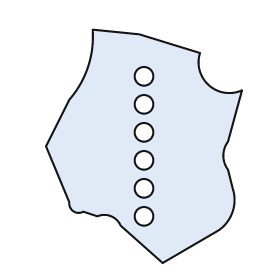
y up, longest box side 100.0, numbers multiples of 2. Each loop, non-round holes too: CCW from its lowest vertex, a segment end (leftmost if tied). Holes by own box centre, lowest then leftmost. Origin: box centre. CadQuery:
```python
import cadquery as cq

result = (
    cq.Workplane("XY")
    .moveTo(8.0, -50.0)
    .lineTo(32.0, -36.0)
    .threePointArc((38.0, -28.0), (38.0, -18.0))
    .lineTo(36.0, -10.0)
    .threePointArc((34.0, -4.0), (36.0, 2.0))
    .lineTo(42.0, 24.0)
    .threePointArc((28.0, 26.0), (24.0, 40.0))
    .lineTo(-2.0, 48.0)
    .lineTo(-22.0, 50.0)
    .threePointArc((-24.0, 34.0), (-32.0, 20.0))
    .lineTo(-42.0, 0.0)
    .lineTo(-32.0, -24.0)
    .threePointArc((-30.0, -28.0), (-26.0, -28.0))
    .lineTo(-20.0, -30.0)
    .threePointArc((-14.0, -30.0), (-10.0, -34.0))
    .close()
    .moveTo(0.0, -30.0)
    .circle(4.0)
    .moveTo(0.0, -18.0)
    .circle(4.0)
    .moveTo(0.0, -6.0)
    .circle(4.0)
    .moveTo(0.0, 6.0)
    .circle(4.0)
    .moveTo(0.0, 18.0)
    .circle(4.0)
    .moveTo(0.0, 30.0)
    .circle(4.0)
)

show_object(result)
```